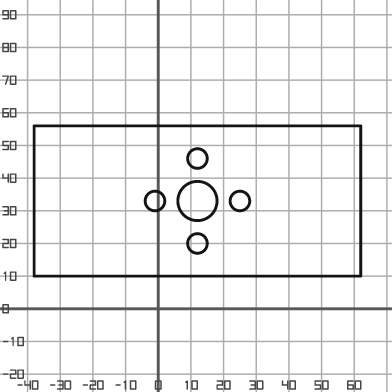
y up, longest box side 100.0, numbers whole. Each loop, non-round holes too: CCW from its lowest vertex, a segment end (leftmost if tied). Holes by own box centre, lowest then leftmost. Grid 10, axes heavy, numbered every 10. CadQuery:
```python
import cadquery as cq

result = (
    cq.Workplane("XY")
    .moveTo(-38.0, 10.0)
    .lineTo(62.0, 10.0)
    .lineTo(62.0, 56.0)
    .lineTo(-38.0, 56.0)
    .close()
    .moveTo(12.0, 20.0)
    .circle(3.0)
    .moveTo(-1.0, 33.0)
    .circle(3.0)
    .moveTo(12.0, 33.0)
    .circle(6.0)
    .moveTo(25.0, 33.0)
    .circle(3.0)
    .moveTo(12.0, 46.0)
    .circle(3.0)
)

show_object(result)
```